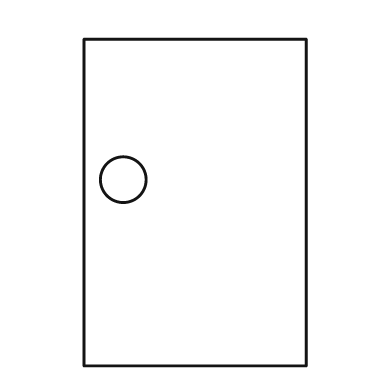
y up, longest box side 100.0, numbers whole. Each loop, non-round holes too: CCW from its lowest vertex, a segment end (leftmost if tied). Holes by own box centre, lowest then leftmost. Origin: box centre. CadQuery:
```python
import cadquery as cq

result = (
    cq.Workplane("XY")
    .moveTo(-34.0, -50.0)
    .lineTo(34.0, -50.0)
    .lineTo(34.0, 50.0)
    .lineTo(-34.0, 50.0)
    .close()
    .moveTo(-22.0, 7.0)
    .circle(7.0)
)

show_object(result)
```